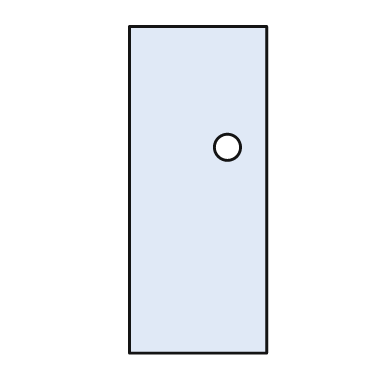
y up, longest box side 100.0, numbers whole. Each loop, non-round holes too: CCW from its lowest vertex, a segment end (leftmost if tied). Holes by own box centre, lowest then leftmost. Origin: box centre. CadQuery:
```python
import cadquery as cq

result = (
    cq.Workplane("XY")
    .moveTo(-21.0, -50.0)
    .lineTo(21.0, -50.0)
    .lineTo(21.0, 50.0)
    .lineTo(-21.0, 50.0)
    .close()
    .moveTo(9.0, 13.0)
    .circle(4.0)
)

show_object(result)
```